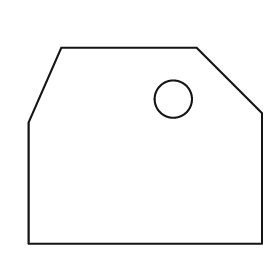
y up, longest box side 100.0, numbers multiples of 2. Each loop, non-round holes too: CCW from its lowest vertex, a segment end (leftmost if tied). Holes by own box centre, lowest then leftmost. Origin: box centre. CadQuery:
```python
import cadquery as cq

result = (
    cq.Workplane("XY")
    .moveTo(-50.0, -42.0)
    .lineTo(50.0, -42.0)
    .lineTo(50.0, 14.0)
    .lineTo(22.0, 42.0)
    .lineTo(-36.0, 42.0)
    .lineTo(-50.0, 10.0)
    .close()
    .moveTo(12.0, 20.0)
    .circle(8.0)
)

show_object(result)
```